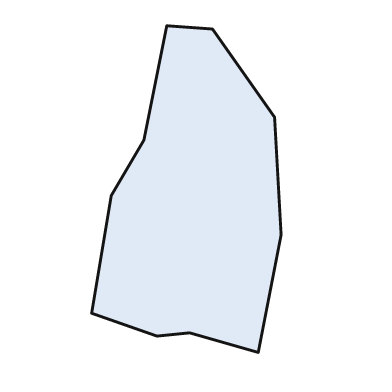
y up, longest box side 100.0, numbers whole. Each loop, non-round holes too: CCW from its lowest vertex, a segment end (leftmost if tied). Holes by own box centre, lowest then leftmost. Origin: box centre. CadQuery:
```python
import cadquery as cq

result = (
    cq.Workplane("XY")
    .moveTo(22.0, -50.0)
    .lineTo(29.0, -14.0)
    .lineTo(27.0, 22.0)
    .lineTo(8.0, 49.0)
    .lineTo(-6.0, 50.0)
    .lineTo(-13.0, 15.0)
    .lineTo(-23.0, -2.0)
    .lineTo(-29.0, -38.0)
    .lineTo(-9.0, -45.0)
    .lineTo(1.0, -44.0)
    .close()
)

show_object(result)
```